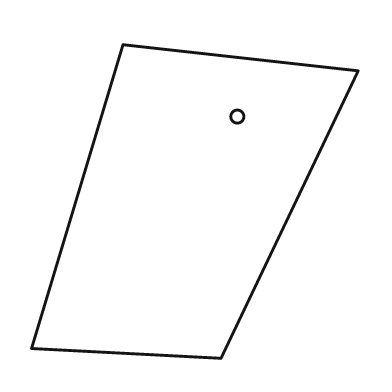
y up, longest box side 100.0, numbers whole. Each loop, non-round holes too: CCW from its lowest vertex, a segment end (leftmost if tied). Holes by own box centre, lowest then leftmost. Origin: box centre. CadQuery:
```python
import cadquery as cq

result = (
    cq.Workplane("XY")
    .moveTo(8.0, -48.0)
    .lineTo(50.0, 40.0)
    .lineTo(-22.0, 48.0)
    .lineTo(-50.0, -45.0)
    .close()
    .moveTo(13.0, 26.0)
    .circle(2.0)
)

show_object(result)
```